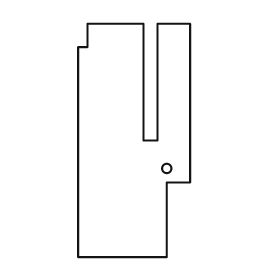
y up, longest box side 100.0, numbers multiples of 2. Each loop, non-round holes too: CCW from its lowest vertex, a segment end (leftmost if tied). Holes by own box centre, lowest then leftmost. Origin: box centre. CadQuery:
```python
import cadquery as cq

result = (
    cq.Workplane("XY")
    .moveTo(-24.0, -50.0)
    .lineTo(14.0, -50.0)
    .lineTo(14.0, -18.0)
    .lineTo(24.0, -18.0)
    .lineTo(24.0, 50.0)
    .lineTo(10.0, 50.0)
    .lineTo(10.0, 0.0)
    .lineTo(4.0, 0.0)
    .lineTo(4.0, 50.0)
    .lineTo(-20.0, 50.0)
    .lineTo(-20.0, 40.0)
    .lineTo(-24.0, 40.0)
    .close()
    .moveTo(14.0, -12.0)
    .circle(2.0)
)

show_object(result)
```